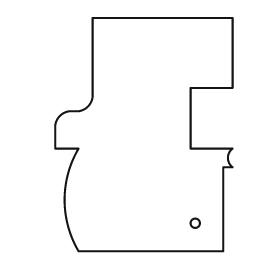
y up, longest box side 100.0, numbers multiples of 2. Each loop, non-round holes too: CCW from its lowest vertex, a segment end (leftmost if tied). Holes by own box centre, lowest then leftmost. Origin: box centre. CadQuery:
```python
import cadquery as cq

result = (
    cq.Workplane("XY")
    .moveTo(-28.0, -50.0)
    .lineTo(34.0, -50.0)
    .lineTo(34.0, -14.0)
    .lineTo(38.0, -14.0)
    .threePointArc((36.0, -10.0), (38.0, -6.0))
    .lineTo(20.0, -6.0)
    .lineTo(20.0, 20.0)
    .lineTo(38.0, 20.0)
    .lineTo(38.0, 50.0)
    .lineTo(-22.0, 50.0)
    .lineTo(-22.0, 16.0)
    .threePointArc((-24.0, 12.0), (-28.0, 10.0))
    .lineTo(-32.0, 10.0)
    .threePointArc((-36.0, 8.0), (-38.0, 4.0))
    .lineTo(-38.0, -6.0)
    .lineTo(-28.0, -6.0)
    .threePointArc((-34.0, -28.0), (-28.0, -50.0))
    .close()
    .moveTo(22.0, -38.0)
    .circle(2.0)
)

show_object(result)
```